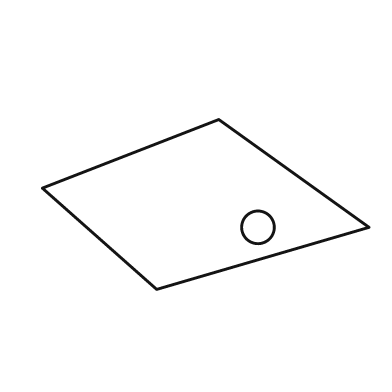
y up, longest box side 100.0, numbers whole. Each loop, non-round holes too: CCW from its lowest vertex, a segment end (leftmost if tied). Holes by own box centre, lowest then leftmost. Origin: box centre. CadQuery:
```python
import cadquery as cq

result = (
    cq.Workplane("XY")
    .moveTo(-15.0, -26.0)
    .lineTo(50.0, -7.0)
    .lineTo(4.0, 26.0)
    .lineTo(-50.0, 5.0)
    .close()
    .moveTo(16.0, -7.0)
    .circle(5.0)
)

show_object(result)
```